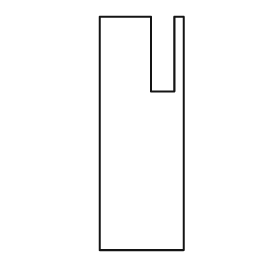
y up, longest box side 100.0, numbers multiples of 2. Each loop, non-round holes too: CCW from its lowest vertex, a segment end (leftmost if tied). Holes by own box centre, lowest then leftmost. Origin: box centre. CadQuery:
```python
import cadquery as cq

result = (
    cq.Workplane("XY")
    .moveTo(-18.0, -50.0)
    .lineTo(18.0, -50.0)
    .lineTo(18.0, 50.0)
    .lineTo(14.0, 50.0)
    .lineTo(14.0, 18.0)
    .lineTo(4.0, 18.0)
    .lineTo(4.0, 50.0)
    .lineTo(-18.0, 50.0)
    .close()
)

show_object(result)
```